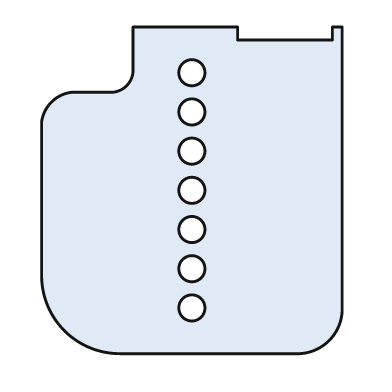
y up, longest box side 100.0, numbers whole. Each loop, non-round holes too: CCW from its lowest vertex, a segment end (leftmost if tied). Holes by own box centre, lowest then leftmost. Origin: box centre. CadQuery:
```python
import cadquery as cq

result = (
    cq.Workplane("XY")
    .moveTo(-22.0, -50.0)
    .lineTo(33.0, -50.0)
    .threePointArc((42.0, -46.0), (46.0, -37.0))
    .lineTo(46.0, 50.0)
    .lineTo(43.0, 50.0)
    .lineTo(43.0, 46.0)
    .lineTo(14.0, 46.0)
    .lineTo(14.0, 50.0)
    .lineTo(-18.0, 50.0)
    .lineTo(-18.0, 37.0)
    .threePointArc((-20.0, 32.0), (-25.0, 30.0))
    .lineTo(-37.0, 30.0)
    .threePointArc((-43.0, 27.0), (-46.0, 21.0))
    .lineTo(-46.0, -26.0)
    .threePointArc((-39.0, -43.0), (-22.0, -50.0))
    .close()
    .moveTo(0.0, -36.0)
    .circle(4.0)
    .moveTo(0.0, -24.0)
    .circle(4.0)
    .moveTo(0.0, -12.0)
    .circle(4.0)
    .moveTo(0.0, 0.0)
    .circle(4.0)
    .moveTo(0.0, 12.0)
    .circle(4.0)
    .moveTo(0.0, 24.0)
    .circle(4.0)
    .moveTo(0.0, 36.0)
    .circle(4.0)
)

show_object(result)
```